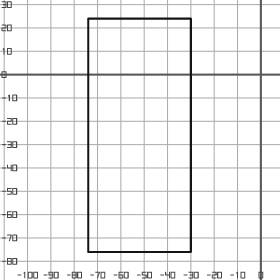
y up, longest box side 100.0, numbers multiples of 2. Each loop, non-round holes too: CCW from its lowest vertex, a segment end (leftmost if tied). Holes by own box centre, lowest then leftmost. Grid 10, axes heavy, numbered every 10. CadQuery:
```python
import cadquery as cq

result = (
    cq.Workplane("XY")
    .moveTo(-74.0, -76.0)
    .lineTo(-30.0, -76.0)
    .lineTo(-30.0, 24.0)
    .lineTo(-74.0, 24.0)
    .close()
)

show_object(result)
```